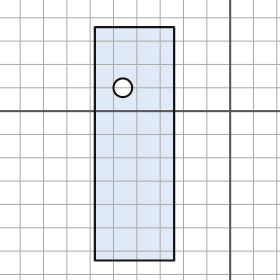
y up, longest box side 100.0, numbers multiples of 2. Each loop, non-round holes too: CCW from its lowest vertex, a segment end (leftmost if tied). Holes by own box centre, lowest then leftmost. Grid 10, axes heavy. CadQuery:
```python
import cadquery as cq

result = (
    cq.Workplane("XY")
    .moveTo(-58.0, -64.0)
    .lineTo(-24.0, -64.0)
    .lineTo(-24.0, 36.0)
    .lineTo(-58.0, 36.0)
    .close()
    .moveTo(-46.0, 10.0)
    .circle(4.0)
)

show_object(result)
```